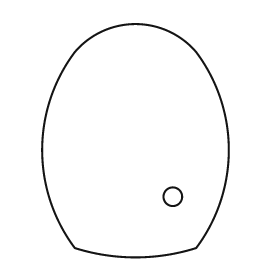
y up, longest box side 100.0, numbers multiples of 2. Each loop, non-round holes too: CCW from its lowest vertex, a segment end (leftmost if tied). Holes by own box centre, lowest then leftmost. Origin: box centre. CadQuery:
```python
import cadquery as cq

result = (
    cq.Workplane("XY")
    .moveTo(-26.0, -46.0)
    .threePointArc((0.0, -50.0), (26.0, -46.0))
    .threePointArc((40.0, -4.0), (26.0, 38.0))
    .threePointArc((0.0, 50.0), (-26.0, 38.0))
    .threePointArc((-40.0, -4.0), (-26.0, -46.0))
    .close()
    .moveTo(16.0, -24.0)
    .circle(4.0)
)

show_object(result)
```